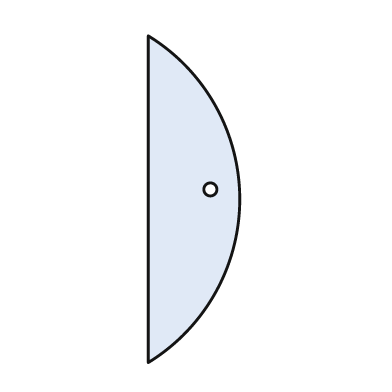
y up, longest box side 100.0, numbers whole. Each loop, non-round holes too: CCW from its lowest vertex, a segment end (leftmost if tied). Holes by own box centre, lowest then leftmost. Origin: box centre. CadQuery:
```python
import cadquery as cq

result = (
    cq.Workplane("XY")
    .moveTo(-14.0, -50.0)
    .threePointArc((14.0, 0.0), (-14.0, 50.0))
    .close()
    .moveTo(5.0, 3.0)
    .circle(2.0)
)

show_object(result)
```